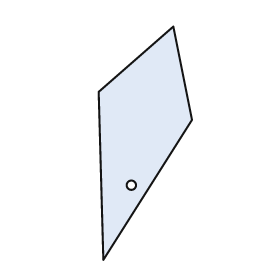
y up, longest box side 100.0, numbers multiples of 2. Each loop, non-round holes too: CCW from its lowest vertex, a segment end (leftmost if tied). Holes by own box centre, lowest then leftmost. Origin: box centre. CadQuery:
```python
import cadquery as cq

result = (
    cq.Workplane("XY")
    .moveTo(-18.0, -50.0)
    .lineTo(20.0, 10.0)
    .lineTo(12.0, 50.0)
    .lineTo(-20.0, 22.0)
    .close()
    .moveTo(-6.0, -18.0)
    .circle(2.0)
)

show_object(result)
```